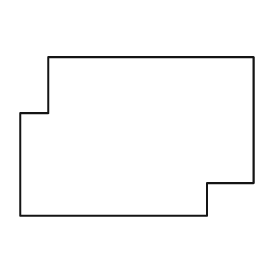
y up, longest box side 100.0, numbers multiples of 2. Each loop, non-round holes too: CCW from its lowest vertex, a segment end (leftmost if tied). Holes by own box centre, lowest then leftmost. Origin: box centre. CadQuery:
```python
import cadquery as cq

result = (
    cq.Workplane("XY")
    .moveTo(-50.0, -34.0)
    .lineTo(30.0, -34.0)
    .lineTo(30.0, -20.0)
    .lineTo(50.0, -20.0)
    .lineTo(50.0, 34.0)
    .lineTo(-38.0, 34.0)
    .lineTo(-38.0, 10.0)
    .lineTo(-50.0, 10.0)
    .close()
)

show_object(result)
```